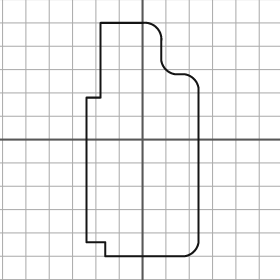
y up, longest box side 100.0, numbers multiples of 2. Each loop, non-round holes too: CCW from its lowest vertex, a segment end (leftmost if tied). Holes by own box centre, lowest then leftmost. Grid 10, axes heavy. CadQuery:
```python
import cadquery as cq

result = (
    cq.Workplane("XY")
    .moveTo(-16.0, -50.0)
    .lineTo(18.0, -50.0)
    .threePointArc((22.0, -48.0), (24.0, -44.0))
    .lineTo(24.0, 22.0)
    .threePointArc((22.0, 26.0), (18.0, 28.0))
    .lineTo(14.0, 28.0)
    .threePointArc((10.0, 30.0), (8.0, 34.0))
    .lineTo(8.0, 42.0)
    .threePointArc((6.0, 48.0), (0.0, 50.0))
    .lineTo(-18.0, 50.0)
    .lineTo(-18.0, 18.0)
    .lineTo(-24.0, 18.0)
    .lineTo(-24.0, -44.0)
    .lineTo(-16.0, -44.0)
    .close()
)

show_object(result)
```